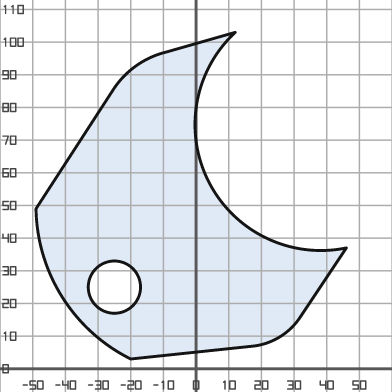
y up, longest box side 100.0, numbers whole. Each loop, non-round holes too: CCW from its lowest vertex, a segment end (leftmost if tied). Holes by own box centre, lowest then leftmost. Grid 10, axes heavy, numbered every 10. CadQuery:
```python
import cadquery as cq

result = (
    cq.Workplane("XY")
    .moveTo(-20.0, 3.0)
    .lineTo(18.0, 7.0)
    .threePointArc((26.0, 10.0), (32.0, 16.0))
    .lineTo(46.0, 37.0)
    .threePointArc((4.0, 57.0), (12.0, 103.0))
    .lineTo(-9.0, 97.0)
    .threePointArc((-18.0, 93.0), (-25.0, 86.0))
    .lineTo(-49.0, 49.0)
    .threePointArc((-41.0, 22.0), (-20.0, 3.0))
    .close()
    .moveTo(-25.0, 25.0)
    .circle(8.0)
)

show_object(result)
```